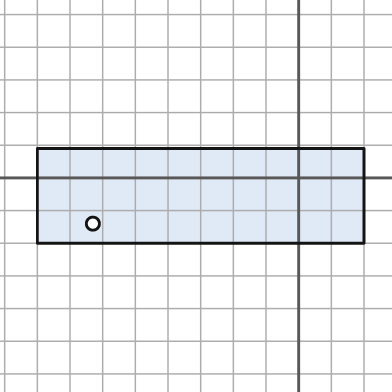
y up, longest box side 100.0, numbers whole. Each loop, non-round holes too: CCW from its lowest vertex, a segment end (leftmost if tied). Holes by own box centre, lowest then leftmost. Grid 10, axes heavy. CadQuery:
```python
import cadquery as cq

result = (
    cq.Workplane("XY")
    .moveTo(-80.0, -20.0)
    .lineTo(20.0, -20.0)
    .lineTo(20.0, 9.0)
    .lineTo(-80.0, 9.0)
    .close()
    .moveTo(-63.0, -14.0)
    .circle(2.0)
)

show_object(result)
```